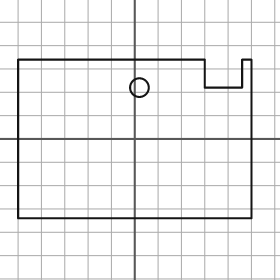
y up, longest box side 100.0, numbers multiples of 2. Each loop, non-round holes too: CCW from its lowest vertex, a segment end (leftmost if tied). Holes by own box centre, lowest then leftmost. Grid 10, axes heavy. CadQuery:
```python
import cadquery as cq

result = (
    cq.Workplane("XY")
    .moveTo(-50.0, -34.0)
    .lineTo(50.0, -34.0)
    .lineTo(50.0, 34.0)
    .lineTo(46.0, 34.0)
    .lineTo(46.0, 22.0)
    .lineTo(30.0, 22.0)
    .lineTo(30.0, 34.0)
    .lineTo(-50.0, 34.0)
    .close()
    .moveTo(2.0, 22.0)
    .circle(4.0)
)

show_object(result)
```